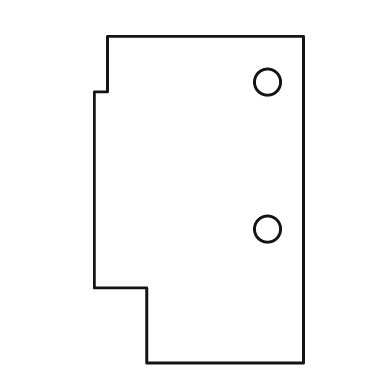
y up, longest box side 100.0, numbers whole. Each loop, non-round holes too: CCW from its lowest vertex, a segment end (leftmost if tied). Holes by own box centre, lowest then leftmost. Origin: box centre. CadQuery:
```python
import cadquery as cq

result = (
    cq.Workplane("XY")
    .moveTo(-16.0, -50.0)
    .lineTo(32.0, -50.0)
    .lineTo(32.0, 50.0)
    .lineTo(-28.0, 50.0)
    .lineTo(-28.0, 33.0)
    .lineTo(-32.0, 33.0)
    .lineTo(-32.0, -27.0)
    .lineTo(-16.0, -27.0)
    .close()
    .moveTo(21.0, -9.0)
    .circle(4.0)
    .moveTo(21.0, 36.0)
    .circle(4.0)
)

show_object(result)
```